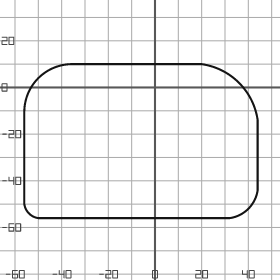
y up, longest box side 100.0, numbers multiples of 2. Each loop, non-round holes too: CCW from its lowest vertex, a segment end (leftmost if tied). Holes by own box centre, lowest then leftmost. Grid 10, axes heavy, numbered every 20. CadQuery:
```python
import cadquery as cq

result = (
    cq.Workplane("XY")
    .moveTo(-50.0, -56.0)
    .lineTo(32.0, -56.0)
    .threePointArc((40.0, -52.0), (44.0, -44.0))
    .lineTo(44.0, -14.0)
    .threePointArc((36.0, 2.0), (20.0, 10.0))
    .lineTo(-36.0, 10.0)
    .threePointArc((-50.0, 4.0), (-56.0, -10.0))
    .lineTo(-56.0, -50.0)
    .threePointArc((-54.0, -54.0), (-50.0, -56.0))
    .close()
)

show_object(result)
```